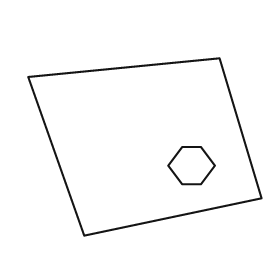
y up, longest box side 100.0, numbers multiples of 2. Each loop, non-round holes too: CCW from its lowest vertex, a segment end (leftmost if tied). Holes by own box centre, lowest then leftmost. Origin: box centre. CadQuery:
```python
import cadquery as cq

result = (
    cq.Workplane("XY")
    .moveTo(-26.0, -38.0)
    .lineTo(50.0, -22.0)
    .lineTo(32.0, 38.0)
    .lineTo(-50.0, 30.0)
    .close()
    .moveTo(16.0, -16.0)
    .lineTo(24.0, -16.0)
    .lineTo(30.0, -8.0)
    .lineTo(24.0, 0.0)
    .lineTo(16.0, 0.0)
    .lineTo(10.0, -8.0)
    .close()
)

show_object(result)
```